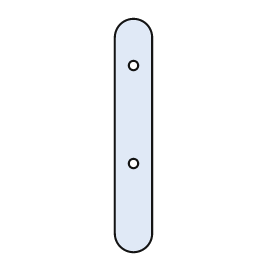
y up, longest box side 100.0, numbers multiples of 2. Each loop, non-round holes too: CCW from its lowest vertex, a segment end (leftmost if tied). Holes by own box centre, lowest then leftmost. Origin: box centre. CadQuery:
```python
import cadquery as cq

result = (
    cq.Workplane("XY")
    .moveTo(-8.0, -42.0)
    .threePointArc((0.0, -50.0), (8.0, -42.0))
    .lineTo(8.0, 42.0)
    .threePointArc((0.0, 50.0), (-8.0, 42.0))
    .close()
    .moveTo(0.0, -12.0)
    .circle(2.0)
    .moveTo(0.0, 30.0)
    .circle(2.0)
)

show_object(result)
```